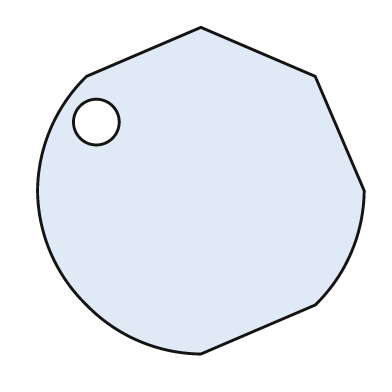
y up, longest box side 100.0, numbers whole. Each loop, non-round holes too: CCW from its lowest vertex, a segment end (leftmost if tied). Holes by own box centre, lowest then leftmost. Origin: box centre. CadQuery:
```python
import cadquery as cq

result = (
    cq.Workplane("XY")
    .moveTo(0.0, -50.0)
    .lineTo(35.0, -35.0)
    .threePointArc((46.0, -19.0), (50.0, 0.0))
    .lineTo(35.0, 35.0)
    .lineTo(0.0, 50.0)
    .lineTo(-35.0, 35.0)
    .threePointArc((-46.0, 19.0), (-50.0, 0.0))
    .threePointArc((-46.0, -19.0), (-35.0, -35.0))
    .threePointArc((-19.0, -46.0), (0.0, -50.0))
    .close()
    .moveTo(-32.0, 21.0)
    .circle(7.0)
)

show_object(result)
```